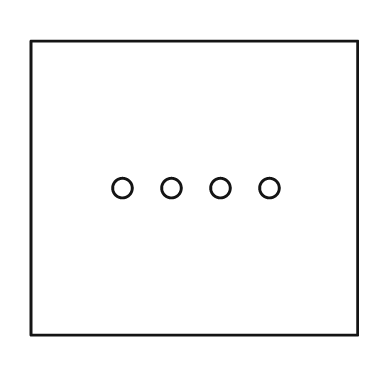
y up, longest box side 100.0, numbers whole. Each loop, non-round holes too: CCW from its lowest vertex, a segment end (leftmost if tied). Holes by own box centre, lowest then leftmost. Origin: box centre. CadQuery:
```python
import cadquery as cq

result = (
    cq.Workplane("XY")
    .moveTo(-50.0, -45.0)
    .lineTo(50.0, -45.0)
    .lineTo(50.0, 45.0)
    .lineTo(-50.0, 45.0)
    .close()
    .moveTo(-22.0, 0.0)
    .circle(3.0)
    .moveTo(-7.0, 0.0)
    .circle(3.0)
    .moveTo(8.0, 0.0)
    .circle(3.0)
    .moveTo(23.0, 0.0)
    .circle(3.0)
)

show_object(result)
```